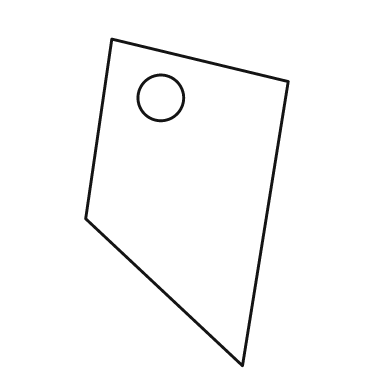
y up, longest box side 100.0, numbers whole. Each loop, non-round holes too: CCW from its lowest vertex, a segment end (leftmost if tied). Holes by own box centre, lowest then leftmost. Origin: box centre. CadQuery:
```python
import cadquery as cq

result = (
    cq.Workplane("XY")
    .moveTo(17.0, -50.0)
    .lineTo(31.0, 37.0)
    .lineTo(-23.0, 50.0)
    .lineTo(-31.0, -5.0)
    .close()
    .moveTo(-8.0, 32.0)
    .circle(7.0)
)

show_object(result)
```